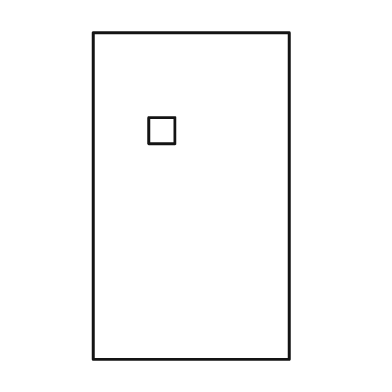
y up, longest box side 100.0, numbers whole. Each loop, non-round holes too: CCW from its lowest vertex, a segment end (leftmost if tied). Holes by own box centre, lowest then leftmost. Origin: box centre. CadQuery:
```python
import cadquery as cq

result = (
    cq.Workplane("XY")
    .moveTo(-30.0, -50.0)
    .lineTo(30.0, -50.0)
    .lineTo(30.0, 50.0)
    .lineTo(-30.0, 50.0)
    .close()
    .moveTo(-13.0, 16.0)
    .lineTo(-5.0, 16.0)
    .lineTo(-5.0, 24.0)
    .lineTo(-13.0, 24.0)
    .close()
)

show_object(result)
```